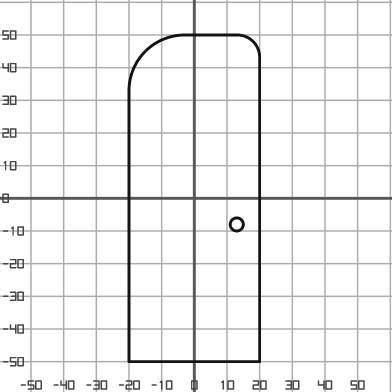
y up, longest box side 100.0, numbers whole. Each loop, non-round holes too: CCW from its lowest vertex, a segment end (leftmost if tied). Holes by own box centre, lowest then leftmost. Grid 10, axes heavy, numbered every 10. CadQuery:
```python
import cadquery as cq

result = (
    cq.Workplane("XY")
    .moveTo(-20.0, -50.0)
    .lineTo(20.0, -50.0)
    .lineTo(20.0, 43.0)
    .threePointArc((18.0, 48.0), (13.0, 50.0))
    .lineTo(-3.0, 50.0)
    .threePointArc((-15.0, 45.0), (-20.0, 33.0))
    .close()
    .moveTo(13.0, -8.0)
    .circle(2.0)
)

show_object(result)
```